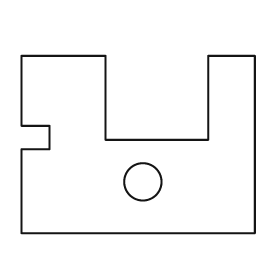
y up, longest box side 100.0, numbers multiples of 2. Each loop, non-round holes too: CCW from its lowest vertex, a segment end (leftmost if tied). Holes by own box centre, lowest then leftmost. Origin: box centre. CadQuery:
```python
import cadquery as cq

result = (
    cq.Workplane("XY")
    .moveTo(-50.0, -38.0)
    .lineTo(50.0, -38.0)
    .lineTo(50.0, 38.0)
    .lineTo(30.0, 38.0)
    .lineTo(30.0, 2.0)
    .lineTo(-14.0, 2.0)
    .lineTo(-14.0, 38.0)
    .lineTo(-50.0, 38.0)
    .lineTo(-50.0, 8.0)
    .lineTo(-38.0, 8.0)
    .lineTo(-38.0, -2.0)
    .lineTo(-50.0, -2.0)
    .close()
    .moveTo(2.0, -16.0)
    .circle(8.0)
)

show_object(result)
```